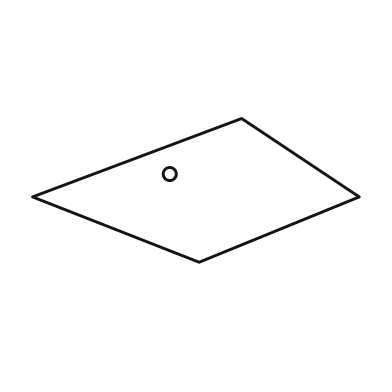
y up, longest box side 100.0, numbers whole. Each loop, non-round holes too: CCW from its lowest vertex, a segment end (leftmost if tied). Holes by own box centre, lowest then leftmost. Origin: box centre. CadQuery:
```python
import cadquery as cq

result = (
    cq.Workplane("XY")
    .moveTo(1.0, -22.0)
    .lineTo(50.0, -2.0)
    .lineTo(14.0, 22.0)
    .lineTo(-50.0, -2.0)
    .close()
    .moveTo(-8.0, 5.0)
    .circle(2.0)
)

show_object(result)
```